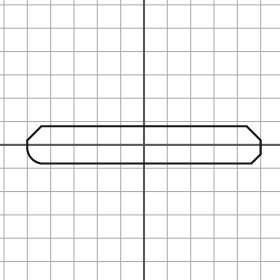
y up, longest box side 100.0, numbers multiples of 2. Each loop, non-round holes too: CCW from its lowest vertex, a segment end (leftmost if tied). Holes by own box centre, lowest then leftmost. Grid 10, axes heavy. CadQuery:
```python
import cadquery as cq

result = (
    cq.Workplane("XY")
    .moveTo(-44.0, -8.0)
    .lineTo(46.0, -8.0)
    .lineTo(50.0, -4.0)
    .lineTo(50.0, 2.0)
    .lineTo(44.0, 8.0)
    .lineTo(-44.0, 8.0)
    .lineTo(-50.0, 2.0)
    .lineTo(-50.0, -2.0)
    .threePointArc((-48.0, -6.0), (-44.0, -8.0))
    .close()
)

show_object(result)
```